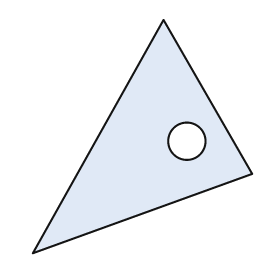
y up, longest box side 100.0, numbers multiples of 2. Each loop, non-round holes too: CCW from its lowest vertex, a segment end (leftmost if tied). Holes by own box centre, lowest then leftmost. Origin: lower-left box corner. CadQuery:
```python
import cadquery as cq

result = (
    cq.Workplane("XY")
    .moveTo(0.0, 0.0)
    .lineTo(94.0, 34.0)
    .lineTo(56.0, 100.0)
    .close()
    .moveTo(66.0, 48.0)
    .circle(8.0)
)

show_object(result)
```